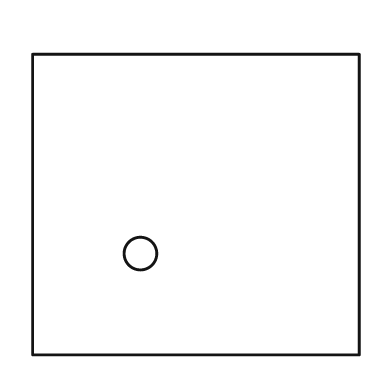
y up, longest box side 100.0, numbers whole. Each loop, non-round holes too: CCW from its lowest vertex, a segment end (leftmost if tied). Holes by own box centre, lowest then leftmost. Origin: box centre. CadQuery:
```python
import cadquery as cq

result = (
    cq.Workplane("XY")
    .moveTo(-50.0, -46.0)
    .lineTo(50.0, -46.0)
    .lineTo(50.0, 46.0)
    .lineTo(-50.0, 46.0)
    .close()
    .moveTo(-17.0, -15.0)
    .circle(5.0)
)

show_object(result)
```